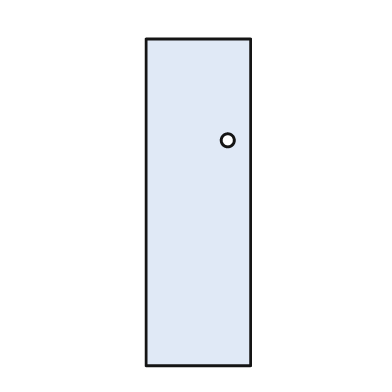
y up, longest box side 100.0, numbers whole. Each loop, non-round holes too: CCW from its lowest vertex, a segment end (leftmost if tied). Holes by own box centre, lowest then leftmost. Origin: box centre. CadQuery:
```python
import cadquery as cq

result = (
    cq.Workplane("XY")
    .moveTo(-16.0, -50.0)
    .lineTo(16.0, -50.0)
    .lineTo(16.0, 50.0)
    .lineTo(-16.0, 50.0)
    .close()
    .moveTo(9.0, 19.0)
    .circle(2.0)
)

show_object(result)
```